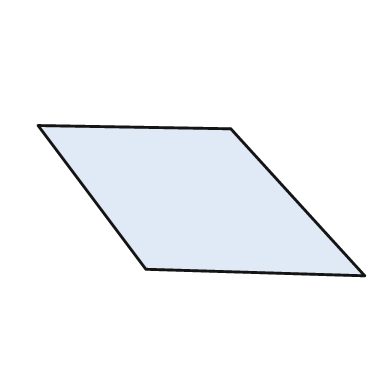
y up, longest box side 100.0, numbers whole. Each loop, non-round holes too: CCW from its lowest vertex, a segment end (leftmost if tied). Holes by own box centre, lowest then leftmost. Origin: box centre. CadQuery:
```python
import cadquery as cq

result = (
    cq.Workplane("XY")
    .moveTo(50.0, -23.0)
    .lineTo(9.0, 22.0)
    .lineTo(-50.0, 23.0)
    .lineTo(-17.0, -21.0)
    .close()
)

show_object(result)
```